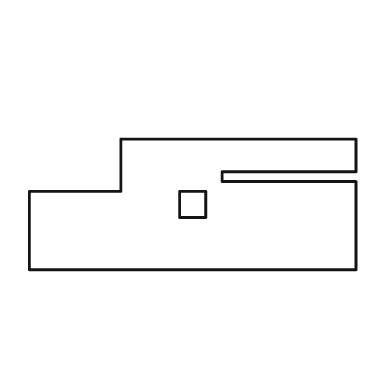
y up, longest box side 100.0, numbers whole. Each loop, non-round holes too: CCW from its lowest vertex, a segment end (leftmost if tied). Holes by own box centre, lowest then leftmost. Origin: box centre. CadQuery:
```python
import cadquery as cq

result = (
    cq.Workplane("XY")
    .moveTo(-50.0, -20.0)
    .lineTo(50.0, -20.0)
    .lineTo(50.0, 7.0)
    .lineTo(9.0, 7.0)
    .lineTo(9.0, 10.0)
    .lineTo(50.0, 10.0)
    .lineTo(50.0, 20.0)
    .lineTo(-22.0, 20.0)
    .lineTo(-22.0, 4.0)
    .lineTo(-50.0, 4.0)
    .close()
    .moveTo(-4.0, -4.0)
    .lineTo(4.0, -4.0)
    .lineTo(4.0, 4.0)
    .lineTo(-4.0, 4.0)
    .close()
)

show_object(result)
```